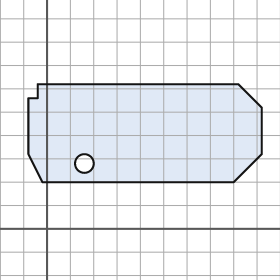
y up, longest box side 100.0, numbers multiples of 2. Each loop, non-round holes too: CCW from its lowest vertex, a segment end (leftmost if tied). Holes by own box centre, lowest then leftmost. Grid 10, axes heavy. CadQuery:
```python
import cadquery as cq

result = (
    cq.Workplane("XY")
    .moveTo(-2.0, 20.0)
    .lineTo(80.0, 20.0)
    .lineTo(92.0, 32.0)
    .lineTo(92.0, 52.0)
    .lineTo(82.0, 62.0)
    .lineTo(-4.0, 62.0)
    .lineTo(-4.0, 56.0)
    .lineTo(-8.0, 56.0)
    .lineTo(-8.0, 32.0)
    .close()
    .moveTo(16.0, 28.0)
    .circle(4.0)
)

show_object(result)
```